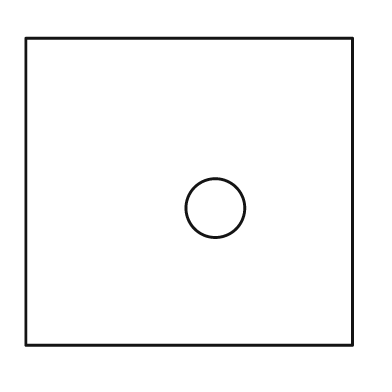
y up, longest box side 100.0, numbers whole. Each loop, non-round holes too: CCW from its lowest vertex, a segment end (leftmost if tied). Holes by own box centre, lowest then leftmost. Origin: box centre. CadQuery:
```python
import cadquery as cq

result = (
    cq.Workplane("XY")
    .moveTo(-50.0, -47.0)
    .lineTo(50.0, -47.0)
    .lineTo(50.0, 47.0)
    .lineTo(-50.0, 47.0)
    .close()
    .moveTo(8.0, -5.0)
    .circle(9.0)
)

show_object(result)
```